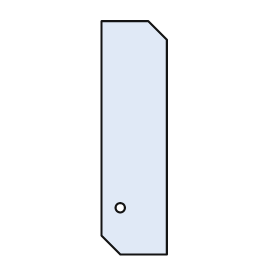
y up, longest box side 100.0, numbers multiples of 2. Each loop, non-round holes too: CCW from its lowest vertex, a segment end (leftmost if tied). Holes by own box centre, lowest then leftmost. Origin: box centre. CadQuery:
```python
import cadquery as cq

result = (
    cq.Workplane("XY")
    .moveTo(-6.0, -50.0)
    .lineTo(14.0, -50.0)
    .lineTo(14.0, 42.0)
    .lineTo(6.0, 50.0)
    .lineTo(-14.0, 50.0)
    .lineTo(-14.0, -42.0)
    .close()
    .moveTo(-6.0, -30.0)
    .circle(2.0)
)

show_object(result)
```